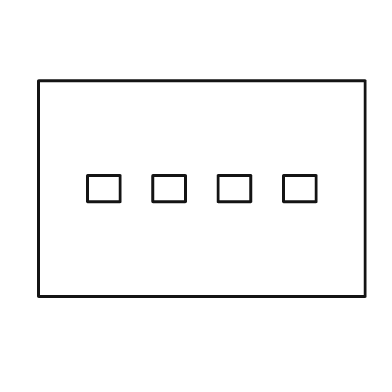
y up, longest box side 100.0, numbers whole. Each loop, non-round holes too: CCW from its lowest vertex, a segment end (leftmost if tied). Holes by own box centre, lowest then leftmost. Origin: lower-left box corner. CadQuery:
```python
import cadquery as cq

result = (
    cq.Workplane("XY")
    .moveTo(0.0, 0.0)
    .lineTo(100.0, 0.0)
    .lineTo(100.0, 66.0)
    .lineTo(0.0, 66.0)
    .close()
    .moveTo(15.0, 29.0)
    .lineTo(25.0, 29.0)
    .lineTo(25.0, 37.0)
    .lineTo(15.0, 37.0)
    .close()
    .moveTo(35.0, 29.0)
    .lineTo(45.0, 29.0)
    .lineTo(45.0, 37.0)
    .lineTo(35.0, 37.0)
    .close()
    .moveTo(55.0, 29.0)
    .lineTo(65.0, 29.0)
    .lineTo(65.0, 37.0)
    .lineTo(55.0, 37.0)
    .close()
    .moveTo(75.0, 29.0)
    .lineTo(85.0, 29.0)
    .lineTo(85.0, 37.0)
    .lineTo(75.0, 37.0)
    .close()
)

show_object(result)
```